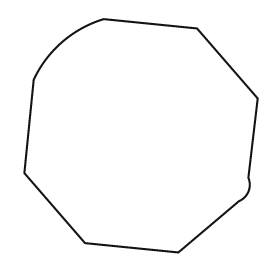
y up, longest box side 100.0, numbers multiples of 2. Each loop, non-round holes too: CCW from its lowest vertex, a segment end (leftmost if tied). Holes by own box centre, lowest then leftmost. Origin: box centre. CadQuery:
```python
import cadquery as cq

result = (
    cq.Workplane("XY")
    .moveTo(16.0, -50.0)
    .lineTo(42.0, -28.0)
    .threePointArc((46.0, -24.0), (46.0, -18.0))
    .lineTo(50.0, 16.0)
    .lineTo(24.0, 46.0)
    .lineTo(-16.0, 50.0)
    .threePointArc((-34.0, 40.0), (-46.0, 24.0))
    .lineTo(-50.0, -16.0)
    .lineTo(-24.0, -46.0)
    .close()
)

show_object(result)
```